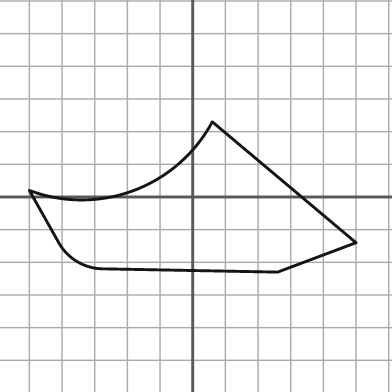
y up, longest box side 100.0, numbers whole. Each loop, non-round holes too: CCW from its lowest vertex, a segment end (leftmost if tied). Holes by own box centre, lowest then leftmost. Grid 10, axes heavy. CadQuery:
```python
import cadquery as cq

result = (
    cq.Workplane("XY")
    .moveTo(26.0, -23.0)
    .lineTo(50.0, -14.0)
    .lineTo(6.0, 23.0)
    .threePointArc((-18.0, 2.0), (-50.0, 2.0))
    .lineTo(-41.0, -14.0)
    .threePointArc((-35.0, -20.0), (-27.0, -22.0))
    .close()
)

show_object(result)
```